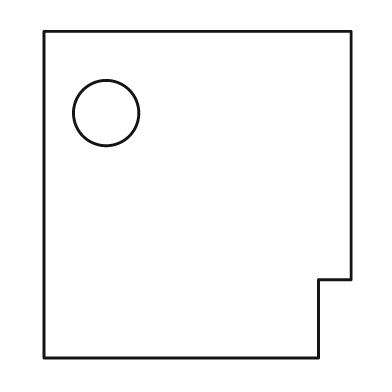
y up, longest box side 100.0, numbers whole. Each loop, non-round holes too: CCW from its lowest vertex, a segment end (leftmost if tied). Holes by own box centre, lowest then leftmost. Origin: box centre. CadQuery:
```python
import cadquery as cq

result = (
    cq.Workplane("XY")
    .moveTo(-47.0, -50.0)
    .lineTo(37.0, -50.0)
    .lineTo(37.0, -26.0)
    .lineTo(47.0, -26.0)
    .lineTo(47.0, 50.0)
    .lineTo(-47.0, 50.0)
    .close()
    .moveTo(-28.0, 25.0)
    .circle(10.0)
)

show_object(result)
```